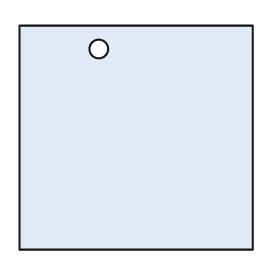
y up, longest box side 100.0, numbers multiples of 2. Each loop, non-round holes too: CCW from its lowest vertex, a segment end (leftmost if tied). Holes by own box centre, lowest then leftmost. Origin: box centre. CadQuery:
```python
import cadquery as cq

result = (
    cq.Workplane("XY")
    .moveTo(-50.0, -48.0)
    .lineTo(50.0, -48.0)
    .lineTo(50.0, 48.0)
    .lineTo(-50.0, 48.0)
    .close()
    .moveTo(-16.0, 38.0)
    .circle(4.0)
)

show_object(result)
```